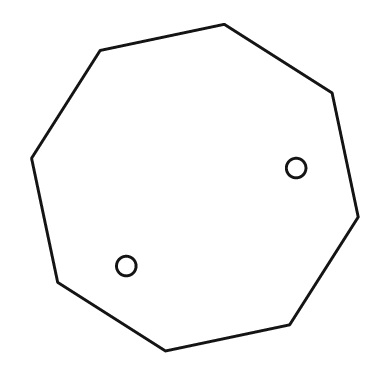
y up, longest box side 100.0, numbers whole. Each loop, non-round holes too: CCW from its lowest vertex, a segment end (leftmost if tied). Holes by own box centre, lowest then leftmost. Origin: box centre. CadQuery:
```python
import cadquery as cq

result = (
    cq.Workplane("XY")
    .moveTo(-9.0, -50.0)
    .lineTo(29.0, -42.0)
    .lineTo(50.0, -9.0)
    .lineTo(42.0, 29.0)
    .lineTo(9.0, 50.0)
    .lineTo(-29.0, 42.0)
    .lineTo(-50.0, 9.0)
    .lineTo(-42.0, -29.0)
    .close()
    .moveTo(-21.0, -24.0)
    .circle(3.0)
    .moveTo(31.0, 6.0)
    .circle(3.0)
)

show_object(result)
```